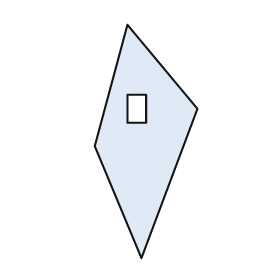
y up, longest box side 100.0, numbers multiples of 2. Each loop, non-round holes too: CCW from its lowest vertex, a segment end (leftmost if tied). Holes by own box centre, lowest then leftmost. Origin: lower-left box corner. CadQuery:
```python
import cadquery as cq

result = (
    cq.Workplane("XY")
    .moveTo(20.0, 0.0)
    .lineTo(44.0, 64.0)
    .lineTo(14.0, 100.0)
    .lineTo(0.0, 48.0)
    .close()
    .moveTo(14.0, 58.0)
    .lineTo(22.0, 58.0)
    .lineTo(22.0, 70.0)
    .lineTo(14.0, 70.0)
    .close()
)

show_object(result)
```